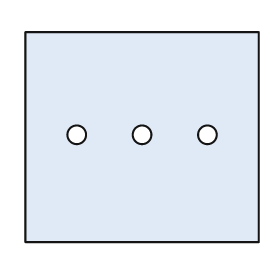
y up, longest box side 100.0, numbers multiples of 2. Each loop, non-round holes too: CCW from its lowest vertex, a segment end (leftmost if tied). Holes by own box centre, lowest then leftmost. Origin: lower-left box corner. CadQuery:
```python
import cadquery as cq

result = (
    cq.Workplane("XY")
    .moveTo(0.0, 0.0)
    .lineTo(100.0, 0.0)
    .lineTo(100.0, 90.0)
    .lineTo(0.0, 90.0)
    .close()
    .moveTo(22.0, 46.0)
    .circle(4.0)
    .moveTo(50.0, 46.0)
    .circle(4.0)
    .moveTo(78.0, 46.0)
    .circle(4.0)
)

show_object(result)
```